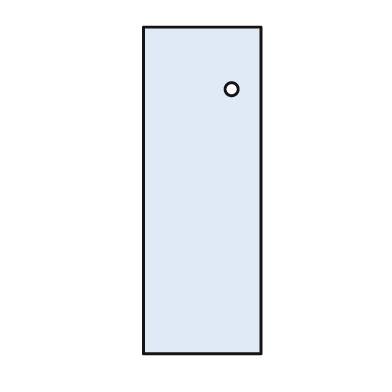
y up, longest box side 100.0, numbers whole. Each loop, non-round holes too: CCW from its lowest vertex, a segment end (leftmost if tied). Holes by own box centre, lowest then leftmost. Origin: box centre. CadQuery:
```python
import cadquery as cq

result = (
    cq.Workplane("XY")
    .moveTo(-18.0, -50.0)
    .lineTo(18.0, -50.0)
    .lineTo(18.0, 50.0)
    .lineTo(-18.0, 50.0)
    .close()
    .moveTo(9.0, 31.0)
    .circle(2.0)
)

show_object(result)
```